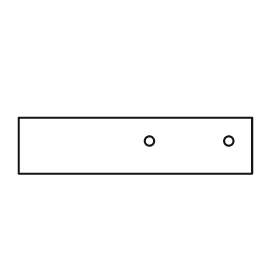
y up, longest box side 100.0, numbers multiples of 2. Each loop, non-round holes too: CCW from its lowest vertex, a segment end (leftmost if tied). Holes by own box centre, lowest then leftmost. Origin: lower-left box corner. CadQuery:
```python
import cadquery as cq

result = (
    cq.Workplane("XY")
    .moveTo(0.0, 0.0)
    .lineTo(100.0, 0.0)
    .lineTo(100.0, 24.0)
    .lineTo(0.0, 24.0)
    .close()
    .moveTo(56.0, 14.0)
    .circle(2.0)
    .moveTo(90.0, 14.0)
    .circle(2.0)
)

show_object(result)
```